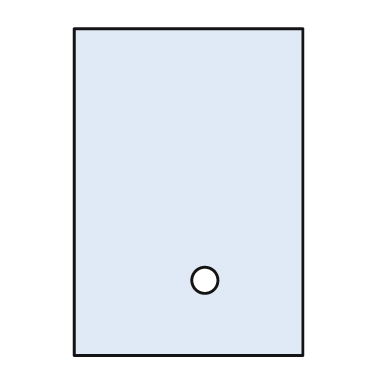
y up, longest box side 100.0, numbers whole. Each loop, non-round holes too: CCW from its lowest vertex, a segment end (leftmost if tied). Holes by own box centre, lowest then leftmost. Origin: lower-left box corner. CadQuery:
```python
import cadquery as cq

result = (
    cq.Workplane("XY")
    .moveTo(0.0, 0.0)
    .lineTo(70.0, 0.0)
    .lineTo(70.0, 100.0)
    .lineTo(0.0, 100.0)
    .close()
    .moveTo(40.0, 23.0)
    .circle(4.0)
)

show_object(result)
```